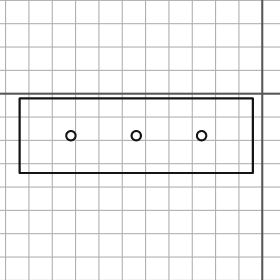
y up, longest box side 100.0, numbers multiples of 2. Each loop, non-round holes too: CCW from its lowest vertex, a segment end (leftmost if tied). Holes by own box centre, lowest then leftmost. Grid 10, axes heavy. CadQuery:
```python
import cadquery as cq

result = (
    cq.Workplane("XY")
    .moveTo(-104.0, -34.0)
    .lineTo(-4.0, -34.0)
    .lineTo(-4.0, -2.0)
    .lineTo(-104.0, -2.0)
    .close()
    .moveTo(-82.0, -18.0)
    .circle(2.0)
    .moveTo(-54.0, -18.0)
    .circle(2.0)
    .moveTo(-26.0, -18.0)
    .circle(2.0)
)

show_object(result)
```